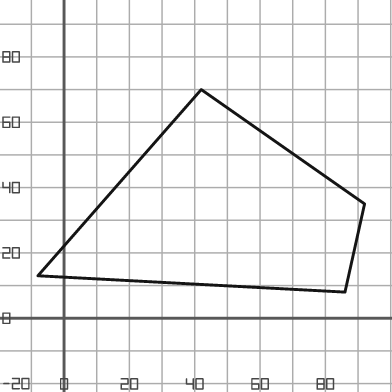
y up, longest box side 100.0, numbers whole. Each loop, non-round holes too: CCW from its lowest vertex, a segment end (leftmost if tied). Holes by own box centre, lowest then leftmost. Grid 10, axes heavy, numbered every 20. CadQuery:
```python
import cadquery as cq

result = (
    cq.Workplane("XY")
    .moveTo(86.0, 8.0)
    .lineTo(92.0, 35.0)
    .lineTo(42.0, 70.0)
    .lineTo(-8.0, 13.0)
    .close()
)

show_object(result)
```